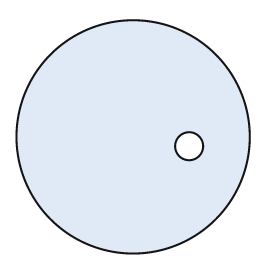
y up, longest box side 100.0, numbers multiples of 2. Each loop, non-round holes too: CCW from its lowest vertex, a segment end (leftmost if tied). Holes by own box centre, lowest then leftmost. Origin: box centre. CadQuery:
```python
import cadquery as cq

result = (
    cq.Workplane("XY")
    .moveTo(0.0, 0.0)
    .circle(50.0)
    .moveTo(24.0, -4.0)
    .circle(6.0)
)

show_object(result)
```